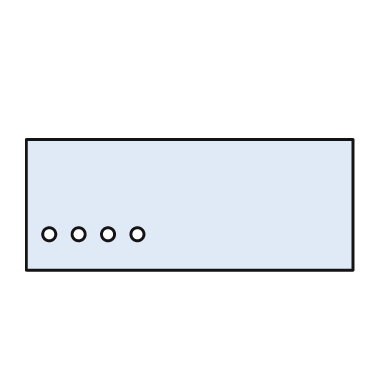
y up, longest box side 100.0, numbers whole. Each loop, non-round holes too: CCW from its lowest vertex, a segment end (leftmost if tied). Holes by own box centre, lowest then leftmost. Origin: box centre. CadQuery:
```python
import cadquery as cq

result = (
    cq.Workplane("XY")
    .moveTo(-50.0, -20.0)
    .lineTo(50.0, -20.0)
    .lineTo(50.0, 20.0)
    .lineTo(-50.0, 20.0)
    .close()
    .moveTo(-43.0, -9.0)
    .circle(2.0)
    .moveTo(-34.0, -9.0)
    .circle(2.0)
    .moveTo(-25.0, -9.0)
    .circle(2.0)
    .moveTo(-16.0, -9.0)
    .circle(2.0)
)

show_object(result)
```